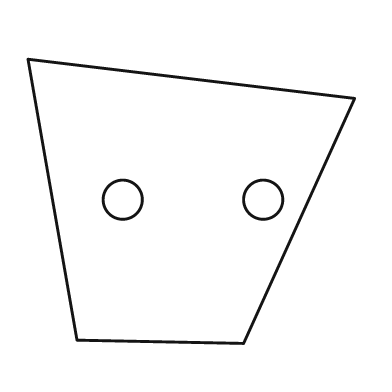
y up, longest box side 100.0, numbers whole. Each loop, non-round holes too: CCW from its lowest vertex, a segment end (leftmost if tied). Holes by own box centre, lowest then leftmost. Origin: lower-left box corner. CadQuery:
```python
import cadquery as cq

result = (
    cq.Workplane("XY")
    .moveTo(66.0, 0.0)
    .lineTo(100.0, 75.0)
    .lineTo(0.0, 87.0)
    .lineTo(15.0, 1.0)
    .close()
    .moveTo(29.0, 44.0)
    .circle(6.0)
    .moveTo(72.0, 44.0)
    .circle(6.0)
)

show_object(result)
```